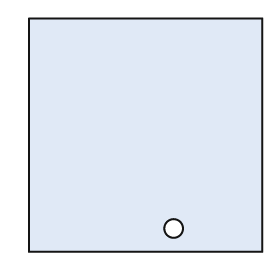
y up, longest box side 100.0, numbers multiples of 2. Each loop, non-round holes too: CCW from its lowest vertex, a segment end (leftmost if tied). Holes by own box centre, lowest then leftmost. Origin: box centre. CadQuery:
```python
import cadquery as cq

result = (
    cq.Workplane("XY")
    .moveTo(-50.0, -50.0)
    .lineTo(50.0, -50.0)
    .lineTo(50.0, 50.0)
    .lineTo(-50.0, 50.0)
    .close()
    .moveTo(12.0, -40.0)
    .circle(4.0)
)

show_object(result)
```